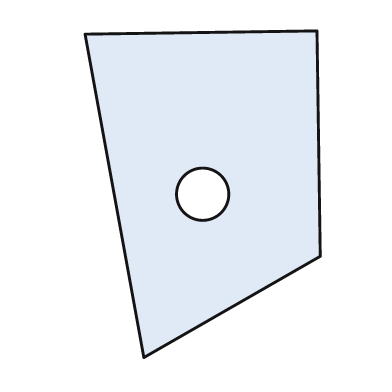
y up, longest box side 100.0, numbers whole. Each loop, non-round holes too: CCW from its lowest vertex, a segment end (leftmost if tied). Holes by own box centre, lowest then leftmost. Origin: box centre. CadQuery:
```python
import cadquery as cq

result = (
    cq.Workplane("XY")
    .moveTo(-18.0, -50.0)
    .lineTo(36.0, -19.0)
    .lineTo(35.0, 50.0)
    .lineTo(-36.0, 49.0)
    .close()
    .moveTo(0.0, 0.0)
    .circle(8.0)
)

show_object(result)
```